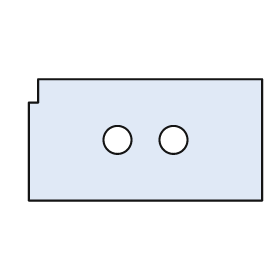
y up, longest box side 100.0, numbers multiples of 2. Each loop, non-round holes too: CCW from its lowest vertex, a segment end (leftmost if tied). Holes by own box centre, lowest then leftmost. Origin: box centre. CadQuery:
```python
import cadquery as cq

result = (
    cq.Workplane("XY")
    .moveTo(-50.0, -26.0)
    .lineTo(50.0, -26.0)
    .lineTo(50.0, 26.0)
    .lineTo(-46.0, 26.0)
    .lineTo(-46.0, 16.0)
    .lineTo(-50.0, 16.0)
    .close()
    .moveTo(-12.0, 0.0)
    .circle(6.0)
    .moveTo(12.0, 0.0)
    .circle(6.0)
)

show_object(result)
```